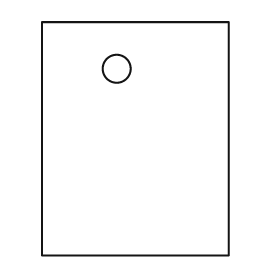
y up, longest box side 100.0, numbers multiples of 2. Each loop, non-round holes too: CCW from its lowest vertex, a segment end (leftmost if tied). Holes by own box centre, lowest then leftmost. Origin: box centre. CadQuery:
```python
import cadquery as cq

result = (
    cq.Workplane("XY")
    .moveTo(-40.0, -50.0)
    .lineTo(40.0, -50.0)
    .lineTo(40.0, 50.0)
    .lineTo(-40.0, 50.0)
    .close()
    .moveTo(-8.0, 30.0)
    .circle(6.0)
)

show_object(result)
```